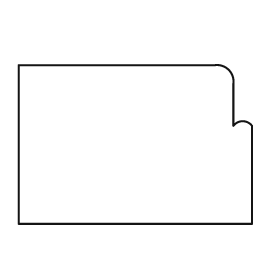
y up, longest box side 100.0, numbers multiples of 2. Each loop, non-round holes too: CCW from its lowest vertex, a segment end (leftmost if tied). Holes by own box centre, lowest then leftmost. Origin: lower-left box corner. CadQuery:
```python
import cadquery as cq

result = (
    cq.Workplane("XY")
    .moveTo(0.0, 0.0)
    .lineTo(100.0, 0.0)
    .lineTo(100.0, 42.0)
    .threePointArc((96.0, 44.0), (92.0, 42.0))
    .lineTo(92.0, 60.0)
    .threePointArc((90.0, 66.0), (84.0, 68.0))
    .lineTo(0.0, 68.0)
    .close()
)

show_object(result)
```